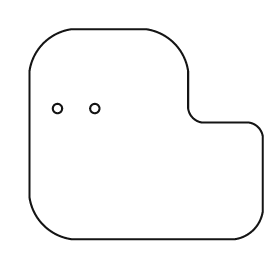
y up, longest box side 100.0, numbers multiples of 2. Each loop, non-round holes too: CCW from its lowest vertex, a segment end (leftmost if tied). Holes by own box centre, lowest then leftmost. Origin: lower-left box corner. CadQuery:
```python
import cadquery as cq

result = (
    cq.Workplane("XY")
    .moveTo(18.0, 0.0)
    .lineTo(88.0, 0.0)
    .threePointArc((96.0, 4.0), (100.0, 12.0))
    .lineTo(100.0, 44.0)
    .threePointArc((98.0, 48.0), (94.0, 50.0))
    .lineTo(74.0, 50.0)
    .threePointArc((70.0, 52.0), (68.0, 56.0))
    .lineTo(68.0, 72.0)
    .threePointArc((62.0, 84.0), (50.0, 90.0))
    .lineTo(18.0, 90.0)
    .threePointArc((6.0, 84.0), (0.0, 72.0))
    .lineTo(0.0, 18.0)
    .threePointArc((6.0, 6.0), (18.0, 0.0))
    .close()
    .moveTo(12.0, 56.0)
    .circle(2.0)
    .moveTo(28.0, 56.0)
    .circle(2.0)
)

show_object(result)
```